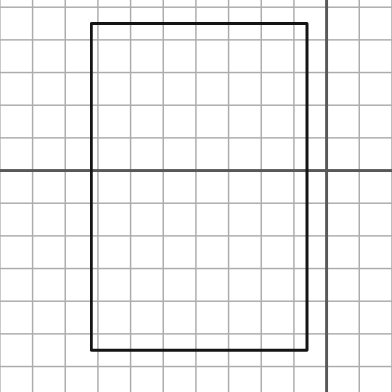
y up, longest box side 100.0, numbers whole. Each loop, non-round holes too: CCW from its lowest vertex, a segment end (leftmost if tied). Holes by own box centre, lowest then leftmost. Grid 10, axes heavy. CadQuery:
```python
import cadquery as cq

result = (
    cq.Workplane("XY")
    .moveTo(-72.0, -55.0)
    .lineTo(-6.0, -55.0)
    .lineTo(-6.0, 45.0)
    .lineTo(-72.0, 45.0)
    .close()
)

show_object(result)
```